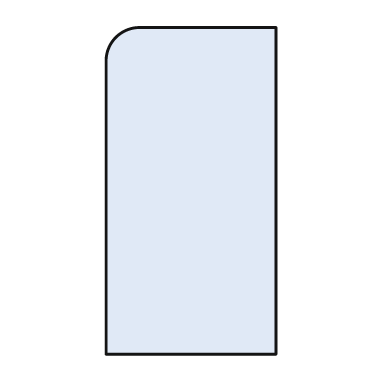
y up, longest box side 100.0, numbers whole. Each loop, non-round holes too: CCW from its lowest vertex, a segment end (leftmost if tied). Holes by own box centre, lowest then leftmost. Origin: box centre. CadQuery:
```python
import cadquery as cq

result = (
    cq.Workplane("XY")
    .moveTo(-26.0, -50.0)
    .lineTo(26.0, -50.0)
    .lineTo(26.0, 50.0)
    .lineTo(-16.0, 50.0)
    .threePointArc((-23.0, 47.0), (-26.0, 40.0))
    .close()
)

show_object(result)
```